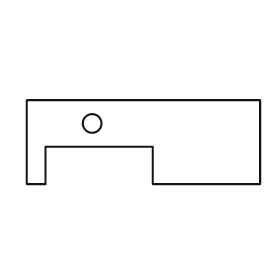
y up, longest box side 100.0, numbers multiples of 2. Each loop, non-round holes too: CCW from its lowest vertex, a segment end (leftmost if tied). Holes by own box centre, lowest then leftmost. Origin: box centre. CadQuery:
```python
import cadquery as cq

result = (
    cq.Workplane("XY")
    .moveTo(-50.0, -18.0)
    .lineTo(-42.0, -18.0)
    .lineTo(-42.0, -2.0)
    .lineTo(4.0, -2.0)
    .lineTo(4.0, -18.0)
    .lineTo(50.0, -18.0)
    .lineTo(50.0, 18.0)
    .lineTo(-50.0, 18.0)
    .close()
    .moveTo(-22.0, 8.0)
    .circle(4.0)
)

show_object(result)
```